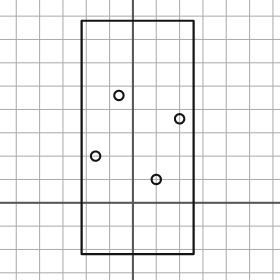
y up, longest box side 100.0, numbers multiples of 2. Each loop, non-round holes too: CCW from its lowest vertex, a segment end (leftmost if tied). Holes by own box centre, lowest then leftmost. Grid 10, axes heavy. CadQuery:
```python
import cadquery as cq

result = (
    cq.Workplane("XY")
    .moveTo(-22.0, -22.0)
    .lineTo(26.0, -22.0)
    .lineTo(26.0, 78.0)
    .lineTo(-22.0, 78.0)
    .close()
    .moveTo(10.0, 10.0)
    .circle(2.0)
    .moveTo(-16.0, 20.0)
    .circle(2.0)
    .moveTo(20.0, 36.0)
    .circle(2.0)
    .moveTo(-6.0, 46.0)
    .circle(2.0)
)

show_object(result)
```